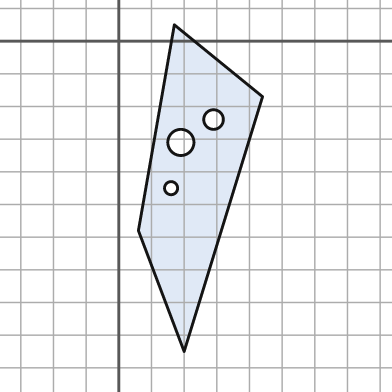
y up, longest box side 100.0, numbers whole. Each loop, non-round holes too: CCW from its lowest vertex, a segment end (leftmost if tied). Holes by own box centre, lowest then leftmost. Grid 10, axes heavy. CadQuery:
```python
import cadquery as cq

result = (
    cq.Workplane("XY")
    .moveTo(20.0, -95.0)
    .lineTo(44.0, -17.0)
    .lineTo(17.0, 5.0)
    .lineTo(6.0, -58.0)
    .close()
    .moveTo(16.0, -45.0)
    .circle(2.0)
    .moveTo(19.0, -31.0)
    .circle(4.0)
    .moveTo(29.0, -24.0)
    .circle(3.0)
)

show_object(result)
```